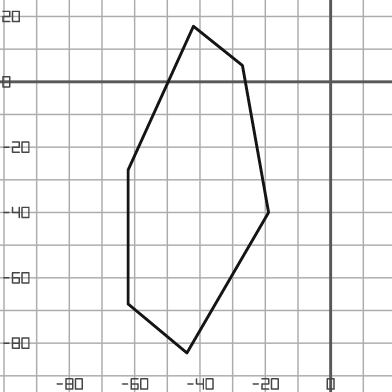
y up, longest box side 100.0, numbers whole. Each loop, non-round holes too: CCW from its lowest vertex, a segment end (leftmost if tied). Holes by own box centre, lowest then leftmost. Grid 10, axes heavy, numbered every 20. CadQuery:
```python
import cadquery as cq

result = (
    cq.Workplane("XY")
    .moveTo(-44.0, -83.0)
    .lineTo(-19.0, -40.0)
    .lineTo(-27.0, 5.0)
    .lineTo(-42.0, 17.0)
    .lineTo(-62.0, -27.0)
    .lineTo(-62.0, -68.0)
    .close()
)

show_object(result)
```